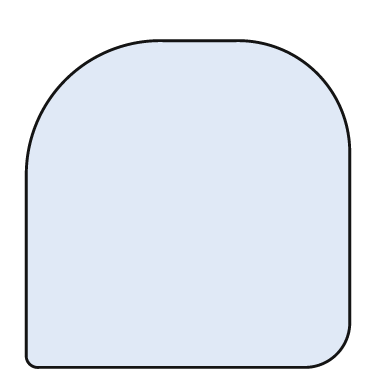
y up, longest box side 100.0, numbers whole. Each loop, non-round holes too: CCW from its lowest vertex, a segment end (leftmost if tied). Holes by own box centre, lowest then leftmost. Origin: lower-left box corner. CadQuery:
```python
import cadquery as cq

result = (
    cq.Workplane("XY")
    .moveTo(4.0, 0.0)
    .lineTo(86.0, 0.0)
    .threePointArc((95.0, 4.0), (99.0, 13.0))
    .lineTo(99.0, 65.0)
    .threePointArc((89.0, 90.0), (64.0, 100.0))
    .lineTo(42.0, 100.0)
    .threePointArc((12.0, 88.0), (0.0, 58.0))
    .lineTo(0.0, 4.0)
    .threePointArc((1.0, 1.0), (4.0, 0.0))
    .close()
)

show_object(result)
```